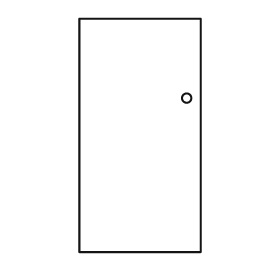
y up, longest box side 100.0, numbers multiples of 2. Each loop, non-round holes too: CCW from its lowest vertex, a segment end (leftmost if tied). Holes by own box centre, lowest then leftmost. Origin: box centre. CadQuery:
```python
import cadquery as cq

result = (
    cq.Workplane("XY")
    .moveTo(-26.0, -50.0)
    .lineTo(26.0, -50.0)
    .lineTo(26.0, 50.0)
    .lineTo(-26.0, 50.0)
    .close()
    .moveTo(20.0, 16.0)
    .circle(2.0)
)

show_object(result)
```